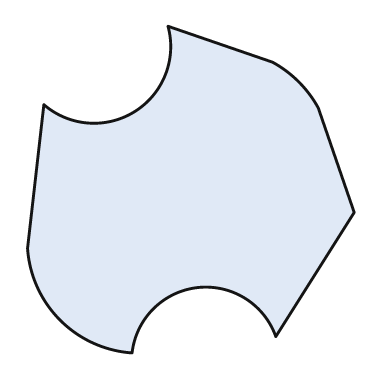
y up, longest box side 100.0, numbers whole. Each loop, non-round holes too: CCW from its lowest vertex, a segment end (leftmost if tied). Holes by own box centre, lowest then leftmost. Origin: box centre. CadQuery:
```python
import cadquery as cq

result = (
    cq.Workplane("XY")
    .moveTo(-18.0, -50.0)
    .threePointArc((2.0, -30.0), (26.0, -45.0))
    .lineTo(50.0, -7.0)
    .lineTo(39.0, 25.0)
    .threePointArc((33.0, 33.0), (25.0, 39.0))
    .lineTo(-7.0, 50.0)
    .threePointArc((-17.0, 24.0), (-45.0, 26.0))
    .lineTo(-50.0, -18.0)
    .threePointArc((-40.0, -40.0), (-18.0, -50.0))
    .close()
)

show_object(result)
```